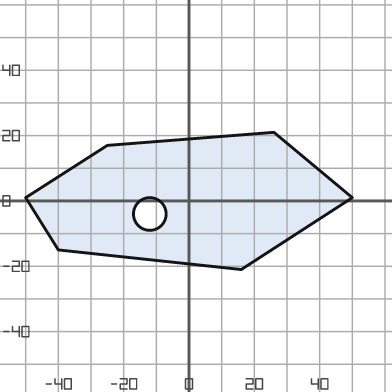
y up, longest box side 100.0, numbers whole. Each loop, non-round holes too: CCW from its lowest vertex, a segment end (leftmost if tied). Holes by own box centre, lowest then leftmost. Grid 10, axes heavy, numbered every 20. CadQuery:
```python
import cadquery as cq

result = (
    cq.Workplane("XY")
    .moveTo(16.0, -21.0)
    .lineTo(50.0, 1.0)
    .lineTo(26.0, 21.0)
    .lineTo(-25.0, 17.0)
    .lineTo(-50.0, 1.0)
    .lineTo(-40.0, -15.0)
    .close()
    .moveTo(-12.0, -4.0)
    .circle(5.0)
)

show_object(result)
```